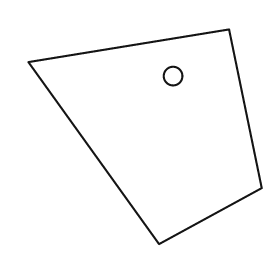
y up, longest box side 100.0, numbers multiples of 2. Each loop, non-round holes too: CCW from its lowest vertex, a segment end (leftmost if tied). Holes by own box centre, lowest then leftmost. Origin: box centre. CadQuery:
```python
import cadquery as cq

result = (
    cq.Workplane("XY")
    .moveTo(6.0, -46.0)
    .lineTo(50.0, -22.0)
    .lineTo(36.0, 46.0)
    .lineTo(-50.0, 32.0)
    .close()
    .moveTo(12.0, 26.0)
    .circle(4.0)
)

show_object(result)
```